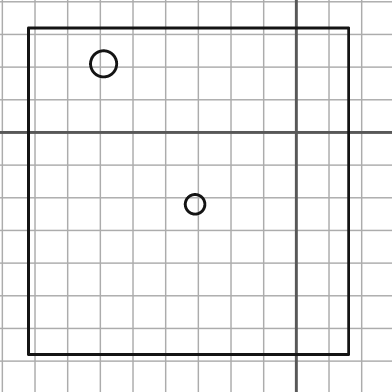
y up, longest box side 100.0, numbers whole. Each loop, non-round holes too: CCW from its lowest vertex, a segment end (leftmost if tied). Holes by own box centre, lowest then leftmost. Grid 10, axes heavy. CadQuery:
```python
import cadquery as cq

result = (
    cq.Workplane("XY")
    .moveTo(-82.0, -68.0)
    .lineTo(16.0, -68.0)
    .lineTo(16.0, 32.0)
    .lineTo(-82.0, 32.0)
    .close()
    .moveTo(-31.0, -22.0)
    .circle(3.0)
    .moveTo(-59.0, 21.0)
    .circle(4.0)
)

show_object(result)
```